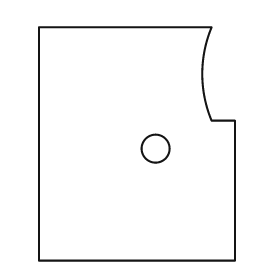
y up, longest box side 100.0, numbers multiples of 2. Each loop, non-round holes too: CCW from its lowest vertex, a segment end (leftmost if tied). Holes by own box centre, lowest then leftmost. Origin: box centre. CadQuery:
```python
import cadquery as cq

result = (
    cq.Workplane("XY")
    .moveTo(-42.0, -50.0)
    .lineTo(42.0, -50.0)
    .lineTo(42.0, 10.0)
    .lineTo(32.0, 10.0)
    .threePointArc((28.0, 30.0), (32.0, 50.0))
    .lineTo(-42.0, 50.0)
    .close()
    .moveTo(8.0, -2.0)
    .circle(6.0)
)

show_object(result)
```